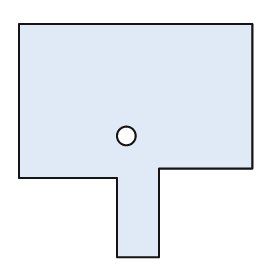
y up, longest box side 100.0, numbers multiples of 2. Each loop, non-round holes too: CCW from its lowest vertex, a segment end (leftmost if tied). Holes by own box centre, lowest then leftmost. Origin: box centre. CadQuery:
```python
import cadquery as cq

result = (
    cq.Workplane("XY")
    .moveTo(-8.0, -50.0)
    .lineTo(10.0, -50.0)
    .lineTo(10.0, -12.0)
    .lineTo(50.0, -12.0)
    .lineTo(50.0, 50.0)
    .lineTo(-50.0, 50.0)
    .lineTo(-50.0, -16.0)
    .lineTo(-8.0, -16.0)
    .close()
    .moveTo(-4.0, 2.0)
    .circle(4.0)
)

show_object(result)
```